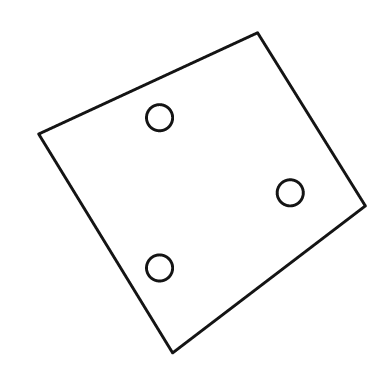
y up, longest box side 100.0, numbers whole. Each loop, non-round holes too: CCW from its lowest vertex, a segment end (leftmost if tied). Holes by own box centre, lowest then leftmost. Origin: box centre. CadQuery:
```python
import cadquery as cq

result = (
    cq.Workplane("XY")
    .moveTo(-9.0, -49.0)
    .lineTo(50.0, -4.0)
    .lineTo(17.0, 49.0)
    .lineTo(-50.0, 18.0)
    .close()
    .moveTo(-13.0, -23.0)
    .circle(4.0)
    .moveTo(27.0, 0.0)
    .circle(4.0)
    .moveTo(-13.0, 23.0)
    .circle(4.0)
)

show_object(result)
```